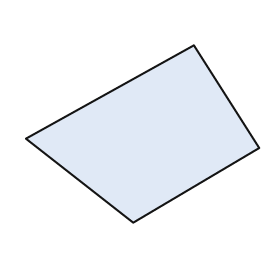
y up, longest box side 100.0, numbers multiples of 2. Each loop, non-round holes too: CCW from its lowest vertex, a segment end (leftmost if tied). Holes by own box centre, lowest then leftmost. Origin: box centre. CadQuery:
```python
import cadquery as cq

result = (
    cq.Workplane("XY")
    .moveTo(-4.0, -38.0)
    .lineTo(50.0, -6.0)
    .lineTo(22.0, 38.0)
    .lineTo(-50.0, -2.0)
    .close()
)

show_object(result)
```